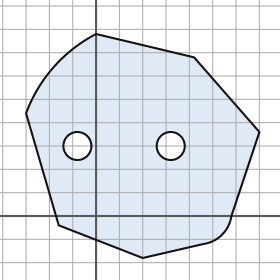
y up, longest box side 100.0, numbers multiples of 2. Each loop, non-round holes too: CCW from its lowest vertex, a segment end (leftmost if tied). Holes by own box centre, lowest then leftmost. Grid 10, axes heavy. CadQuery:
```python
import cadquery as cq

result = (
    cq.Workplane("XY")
    .moveTo(20.0, -18.0)
    .lineTo(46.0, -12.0)
    .threePointArc((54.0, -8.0), (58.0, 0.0))
    .lineTo(70.0, 36.0)
    .lineTo(42.0, 68.0)
    .lineTo(0.0, 78.0)
    .threePointArc((-18.0, 64.0), (-30.0, 44.0))
    .lineTo(-16.0, -4.0)
    .close()
    .moveTo(-8.0, 30.0)
    .circle(6.0)
    .moveTo(32.0, 30.0)
    .circle(6.0)
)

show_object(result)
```